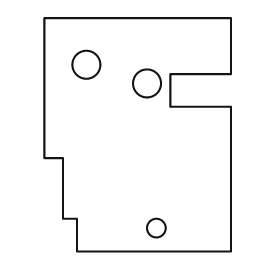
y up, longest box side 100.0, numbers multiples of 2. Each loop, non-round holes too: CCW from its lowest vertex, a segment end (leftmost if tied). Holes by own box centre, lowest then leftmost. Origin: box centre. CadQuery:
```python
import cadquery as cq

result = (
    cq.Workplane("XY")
    .moveTo(-26.0, -50.0)
    .lineTo(40.0, -50.0)
    .lineTo(40.0, 12.0)
    .lineTo(14.0, 12.0)
    .lineTo(14.0, 26.0)
    .lineTo(40.0, 26.0)
    .lineTo(40.0, 50.0)
    .lineTo(-40.0, 50.0)
    .lineTo(-40.0, -10.0)
    .lineTo(-32.0, -10.0)
    .lineTo(-32.0, -36.0)
    .lineTo(-26.0, -36.0)
    .close()
    .moveTo(8.0, -40.0)
    .circle(4.0)
    .moveTo(4.0, 22.0)
    .circle(6.0)
    .moveTo(-22.0, 30.0)
    .circle(6.0)
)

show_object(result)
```